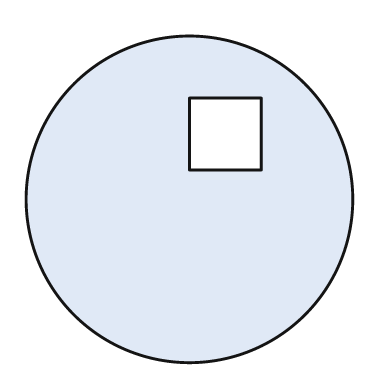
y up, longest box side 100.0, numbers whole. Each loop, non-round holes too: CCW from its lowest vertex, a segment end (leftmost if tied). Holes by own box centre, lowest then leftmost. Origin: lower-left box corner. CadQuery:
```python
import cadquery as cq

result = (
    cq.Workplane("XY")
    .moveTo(50.0, 50.0)
    .circle(50.0)
    .moveTo(50.0, 59.0)
    .lineTo(72.0, 59.0)
    .lineTo(72.0, 81.0)
    .lineTo(50.0, 81.0)
    .close()
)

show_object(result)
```